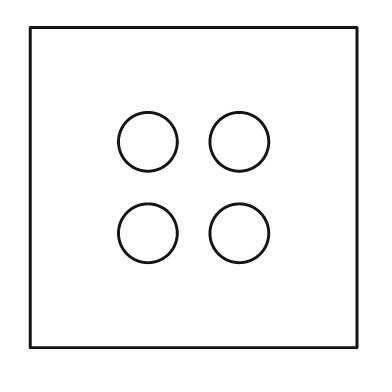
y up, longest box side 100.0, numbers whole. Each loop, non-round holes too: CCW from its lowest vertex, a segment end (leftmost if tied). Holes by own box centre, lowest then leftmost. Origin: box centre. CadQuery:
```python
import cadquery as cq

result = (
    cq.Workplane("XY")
    .moveTo(-50.0, -49.0)
    .lineTo(50.0, -49.0)
    .lineTo(50.0, 49.0)
    .lineTo(-50.0, 49.0)
    .close()
    .moveTo(-14.0, -14.0)
    .circle(9.0)
    .moveTo(14.0, -14.0)
    .circle(9.0)
    .moveTo(-14.0, 14.0)
    .circle(9.0)
    .moveTo(14.0, 14.0)
    .circle(9.0)
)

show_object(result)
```